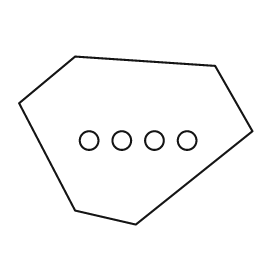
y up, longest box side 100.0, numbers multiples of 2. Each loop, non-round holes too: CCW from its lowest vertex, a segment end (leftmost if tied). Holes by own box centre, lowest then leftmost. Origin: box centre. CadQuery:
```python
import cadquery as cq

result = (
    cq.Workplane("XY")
    .moveTo(0.0, -36.0)
    .lineTo(50.0, 4.0)
    .lineTo(34.0, 32.0)
    .lineTo(-26.0, 36.0)
    .lineTo(-50.0, 16.0)
    .lineTo(-26.0, -30.0)
    .close()
    .moveTo(-20.0, 0.0)
    .circle(4.0)
    .moveTo(-6.0, 0.0)
    .circle(4.0)
    .moveTo(8.0, 0.0)
    .circle(4.0)
    .moveTo(22.0, 0.0)
    .circle(4.0)
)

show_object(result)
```